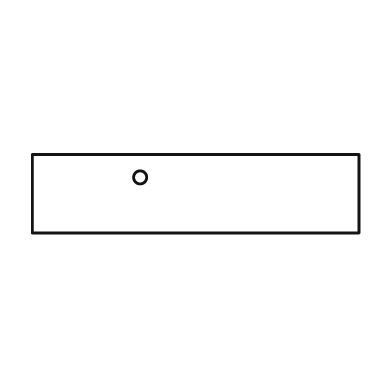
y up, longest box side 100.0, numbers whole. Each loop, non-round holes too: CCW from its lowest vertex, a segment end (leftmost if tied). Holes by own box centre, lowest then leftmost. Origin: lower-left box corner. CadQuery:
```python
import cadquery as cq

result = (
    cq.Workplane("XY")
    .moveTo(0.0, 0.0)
    .lineTo(100.0, 0.0)
    .lineTo(100.0, 24.0)
    .lineTo(0.0, 24.0)
    .close()
    .moveTo(33.0, 17.0)
    .circle(2.0)
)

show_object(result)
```